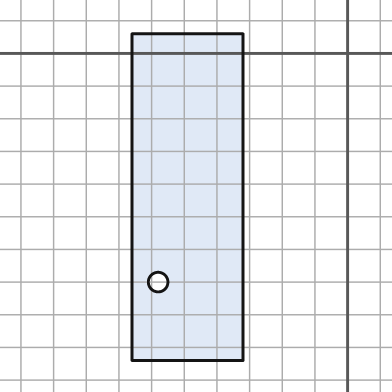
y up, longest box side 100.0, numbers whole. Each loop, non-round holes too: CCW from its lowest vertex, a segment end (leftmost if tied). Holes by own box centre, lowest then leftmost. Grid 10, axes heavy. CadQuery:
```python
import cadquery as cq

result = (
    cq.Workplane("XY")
    .moveTo(-66.0, -94.0)
    .lineTo(-32.0, -94.0)
    .lineTo(-32.0, 6.0)
    .lineTo(-66.0, 6.0)
    .close()
    .moveTo(-58.0, -70.0)
    .circle(3.0)
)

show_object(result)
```